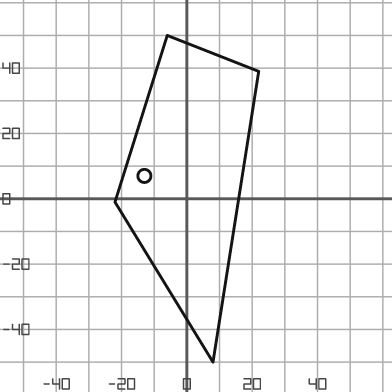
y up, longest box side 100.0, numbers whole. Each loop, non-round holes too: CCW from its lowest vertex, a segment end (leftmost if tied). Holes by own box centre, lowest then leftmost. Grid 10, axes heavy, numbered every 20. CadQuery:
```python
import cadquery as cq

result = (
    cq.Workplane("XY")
    .moveTo(8.0, -50.0)
    .lineTo(22.0, 39.0)
    .lineTo(-6.0, 50.0)
    .lineTo(-22.0, -1.0)
    .close()
    .moveTo(-13.0, 7.0)
    .circle(2.0)
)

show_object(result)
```